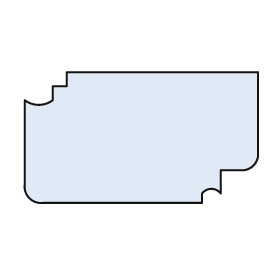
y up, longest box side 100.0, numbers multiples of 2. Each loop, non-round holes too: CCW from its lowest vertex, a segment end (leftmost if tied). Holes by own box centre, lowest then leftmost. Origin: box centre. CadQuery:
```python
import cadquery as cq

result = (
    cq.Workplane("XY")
    .moveTo(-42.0, -28.0)
    .lineTo(26.0, -28.0)
    .lineTo(26.0, -24.0)
    .threePointArc((30.0, -22.0), (34.0, -24.0))
    .lineTo(34.0, -14.0)
    .lineTo(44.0, -14.0)
    .threePointArc((48.0, -12.0), (50.0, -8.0))
    .lineTo(50.0, 28.0)
    .lineTo(-32.0, 28.0)
    .lineTo(-32.0, 22.0)
    .lineTo(-38.0, 22.0)
    .lineTo(-38.0, 16.0)
    .threePointArc((-44.0, 14.0), (-50.0, 16.0))
    .lineTo(-50.0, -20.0)
    .threePointArc((-48.0, -26.0), (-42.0, -28.0))
    .close()
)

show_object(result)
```